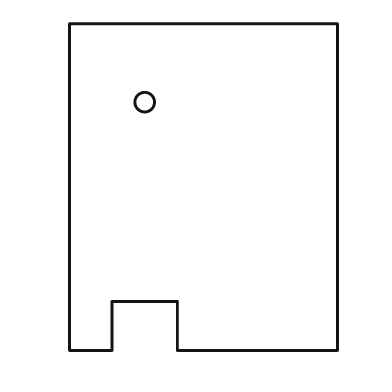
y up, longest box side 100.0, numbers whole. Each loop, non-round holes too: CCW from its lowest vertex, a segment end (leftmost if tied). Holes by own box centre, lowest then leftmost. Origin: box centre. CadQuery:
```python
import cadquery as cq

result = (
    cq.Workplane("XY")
    .moveTo(-41.0, -50.0)
    .lineTo(-28.0, -50.0)
    .lineTo(-28.0, -35.0)
    .lineTo(-8.0, -35.0)
    .lineTo(-8.0, -50.0)
    .lineTo(41.0, -50.0)
    .lineTo(41.0, 50.0)
    .lineTo(-41.0, 50.0)
    .close()
    .moveTo(-18.0, 26.0)
    .circle(3.0)
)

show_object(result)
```